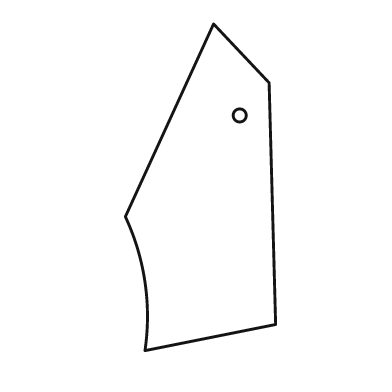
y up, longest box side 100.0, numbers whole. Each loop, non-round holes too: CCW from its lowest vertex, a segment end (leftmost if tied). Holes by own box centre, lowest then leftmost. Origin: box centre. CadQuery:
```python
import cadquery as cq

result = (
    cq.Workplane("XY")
    .moveTo(-17.0, -50.0)
    .lineTo(23.0, -42.0)
    .lineTo(21.0, 32.0)
    .lineTo(4.0, 50.0)
    .lineTo(-23.0, -9.0)
    .threePointArc((-17.0, -29.0), (-17.0, -50.0))
    .close()
    .moveTo(12.0, 22.0)
    .circle(2.0)
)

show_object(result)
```